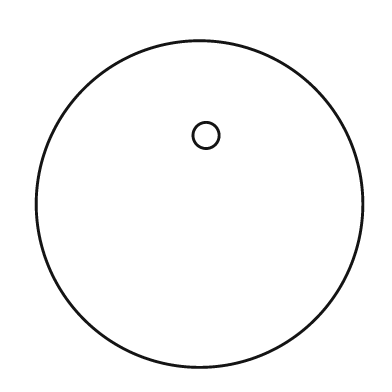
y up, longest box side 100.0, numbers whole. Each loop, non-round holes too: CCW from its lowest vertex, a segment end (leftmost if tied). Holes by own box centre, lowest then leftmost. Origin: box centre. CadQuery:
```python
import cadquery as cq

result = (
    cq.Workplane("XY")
    .moveTo(0.0, 0.0)
    .circle(50.0)
    .moveTo(2.0, 21.0)
    .circle(4.0)
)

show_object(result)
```